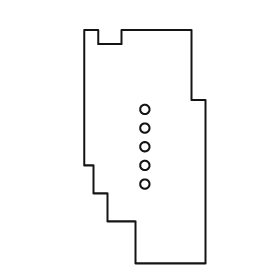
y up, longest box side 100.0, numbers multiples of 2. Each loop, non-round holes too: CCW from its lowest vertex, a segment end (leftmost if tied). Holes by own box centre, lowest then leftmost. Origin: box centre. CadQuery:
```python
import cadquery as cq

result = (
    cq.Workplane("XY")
    .moveTo(-4.0, -50.0)
    .lineTo(26.0, -50.0)
    .lineTo(26.0, 20.0)
    .lineTo(20.0, 20.0)
    .lineTo(20.0, 50.0)
    .lineTo(-10.0, 50.0)
    .lineTo(-10.0, 44.0)
    .lineTo(-20.0, 44.0)
    .lineTo(-20.0, 50.0)
    .lineTo(-26.0, 50.0)
    .lineTo(-26.0, -8.0)
    .lineTo(-22.0, -8.0)
    .lineTo(-22.0, -20.0)
    .lineTo(-16.0, -20.0)
    .lineTo(-16.0, -32.0)
    .lineTo(-4.0, -32.0)
    .close()
    .moveTo(0.0, -16.0)
    .circle(2.0)
    .moveTo(0.0, -8.0)
    .circle(2.0)
    .moveTo(0.0, 0.0)
    .circle(2.0)
    .moveTo(0.0, 8.0)
    .circle(2.0)
    .moveTo(0.0, 16.0)
    .circle(2.0)
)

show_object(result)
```